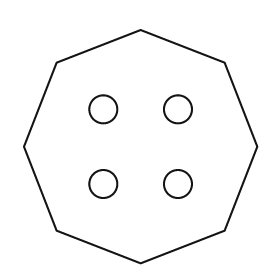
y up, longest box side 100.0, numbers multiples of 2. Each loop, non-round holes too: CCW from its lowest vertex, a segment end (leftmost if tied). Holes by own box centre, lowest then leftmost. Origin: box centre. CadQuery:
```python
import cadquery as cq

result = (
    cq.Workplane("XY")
    .moveTo(0.0, -50.0)
    .lineTo(36.0, -36.0)
    .lineTo(50.0, 0.0)
    .lineTo(36.0, 36.0)
    .lineTo(0.0, 50.0)
    .lineTo(-36.0, 36.0)
    .lineTo(-50.0, 0.0)
    .lineTo(-36.0, -36.0)
    .close()
    .moveTo(-16.0, -16.0)
    .circle(6.0)
    .moveTo(16.0, -16.0)
    .circle(6.0)
    .moveTo(-16.0, 16.0)
    .circle(6.0)
    .moveTo(16.0, 16.0)
    .circle(6.0)
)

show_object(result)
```